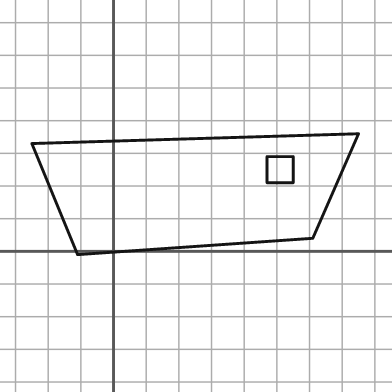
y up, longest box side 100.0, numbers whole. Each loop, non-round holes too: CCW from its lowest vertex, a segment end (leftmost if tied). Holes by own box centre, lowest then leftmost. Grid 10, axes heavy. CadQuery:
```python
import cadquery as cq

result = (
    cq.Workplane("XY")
    .moveTo(-11.0, -1.0)
    .lineTo(61.0, 4.0)
    .lineTo(75.0, 36.0)
    .lineTo(-25.0, 33.0)
    .close()
    .moveTo(47.0, 21.0)
    .lineTo(55.0, 21.0)
    .lineTo(55.0, 29.0)
    .lineTo(47.0, 29.0)
    .close()
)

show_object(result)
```